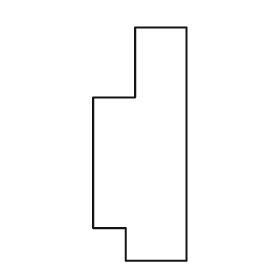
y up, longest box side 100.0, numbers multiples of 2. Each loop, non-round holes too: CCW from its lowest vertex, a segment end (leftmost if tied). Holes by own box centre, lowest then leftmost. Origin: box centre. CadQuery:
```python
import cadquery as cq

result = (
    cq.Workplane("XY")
    .moveTo(-6.0, -50.0)
    .lineTo(20.0, -50.0)
    .lineTo(20.0, 50.0)
    .lineTo(-2.0, 50.0)
    .lineTo(-2.0, 20.0)
    .lineTo(-20.0, 20.0)
    .lineTo(-20.0, -36.0)
    .lineTo(-6.0, -36.0)
    .close()
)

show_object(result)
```